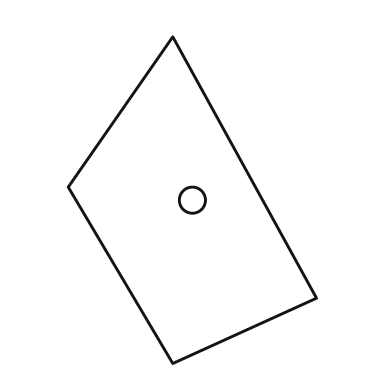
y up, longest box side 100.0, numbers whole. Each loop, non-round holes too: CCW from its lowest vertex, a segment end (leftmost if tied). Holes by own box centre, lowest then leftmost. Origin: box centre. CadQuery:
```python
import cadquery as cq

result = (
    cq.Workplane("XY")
    .moveTo(-6.0, -50.0)
    .lineTo(38.0, -30.0)
    .lineTo(-6.0, 50.0)
    .lineTo(-38.0, 4.0)
    .close()
    .moveTo(0.0, 0.0)
    .circle(4.0)
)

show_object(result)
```